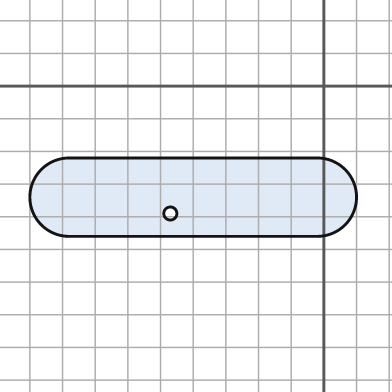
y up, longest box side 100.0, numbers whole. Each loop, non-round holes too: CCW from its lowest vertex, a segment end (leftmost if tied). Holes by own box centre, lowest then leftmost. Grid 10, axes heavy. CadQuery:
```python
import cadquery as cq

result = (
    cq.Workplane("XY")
    .moveTo(-78.0, -46.0)
    .lineTo(-2.0, -46.0)
    .threePointArc((10.0, -34.0), (-2.0, -22.0))
    .lineTo(-78.0, -22.0)
    .threePointArc((-90.0, -34.0), (-78.0, -46.0))
    .close()
    .moveTo(-47.0, -39.0)
    .circle(2.0)
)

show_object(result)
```